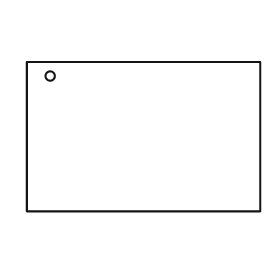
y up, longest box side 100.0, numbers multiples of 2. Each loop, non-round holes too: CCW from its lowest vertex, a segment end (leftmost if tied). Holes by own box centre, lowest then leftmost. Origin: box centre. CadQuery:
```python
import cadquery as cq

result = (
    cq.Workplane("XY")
    .moveTo(-50.0, -32.0)
    .lineTo(50.0, -32.0)
    .lineTo(50.0, 32.0)
    .lineTo(-50.0, 32.0)
    .close()
    .moveTo(-40.0, 26.0)
    .circle(2.0)
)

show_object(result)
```